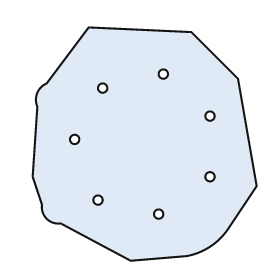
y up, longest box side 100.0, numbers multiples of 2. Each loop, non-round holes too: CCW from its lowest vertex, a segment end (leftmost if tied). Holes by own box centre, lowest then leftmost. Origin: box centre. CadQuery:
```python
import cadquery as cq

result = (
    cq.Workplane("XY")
    .moveTo(-6.0, -50.0)
    .lineTo(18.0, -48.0)
    .threePointArc((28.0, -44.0), (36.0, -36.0))
    .lineTo(48.0, -18.0)
    .lineTo(40.0, 28.0)
    .lineTo(20.0, 48.0)
    .lineTo(-24.0, 50.0)
    .lineTo(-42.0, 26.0)
    .threePointArc((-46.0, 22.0), (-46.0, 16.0))
    .lineTo(-48.0, -14.0)
    .lineTo(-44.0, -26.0)
    .threePointArc((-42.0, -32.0), (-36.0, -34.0))
    .close()
    .moveTo(6.0, -30.0)
    .circle(2.0)
    .moveTo(-20.0, -24.0)
    .circle(2.0)
    .moveTo(28.0, -14.0)
    .circle(2.0)
    .moveTo(-30.0, 2.0)
    .circle(2.0)
    .moveTo(28.0, 12.0)
    .circle(2.0)
    .moveTo(-18.0, 24.0)
    .circle(2.0)
    .moveTo(8.0, 30.0)
    .circle(2.0)
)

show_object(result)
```